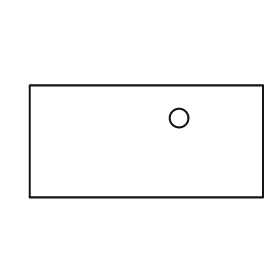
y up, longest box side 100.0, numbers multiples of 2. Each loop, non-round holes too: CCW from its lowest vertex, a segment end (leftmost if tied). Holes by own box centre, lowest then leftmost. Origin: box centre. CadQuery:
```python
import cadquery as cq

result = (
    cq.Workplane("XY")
    .moveTo(-50.0, -24.0)
    .lineTo(50.0, -24.0)
    .lineTo(50.0, 24.0)
    .lineTo(-50.0, 24.0)
    .close()
    .moveTo(14.0, 10.0)
    .circle(4.0)
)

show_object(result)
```